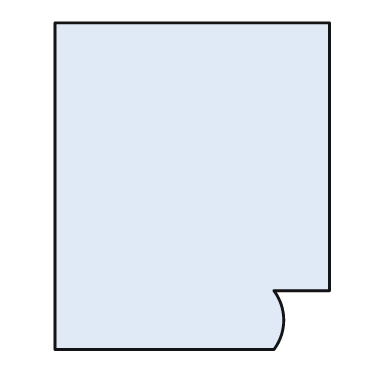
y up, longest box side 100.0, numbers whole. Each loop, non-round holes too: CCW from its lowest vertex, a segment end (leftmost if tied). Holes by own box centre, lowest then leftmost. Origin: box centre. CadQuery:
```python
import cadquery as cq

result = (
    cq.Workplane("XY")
    .moveTo(-42.0, -50.0)
    .lineTo(25.0, -50.0)
    .threePointArc((28.0, -41.0), (25.0, -32.0))
    .lineTo(42.0, -32.0)
    .lineTo(42.0, 50.0)
    .lineTo(-42.0, 50.0)
    .close()
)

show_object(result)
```